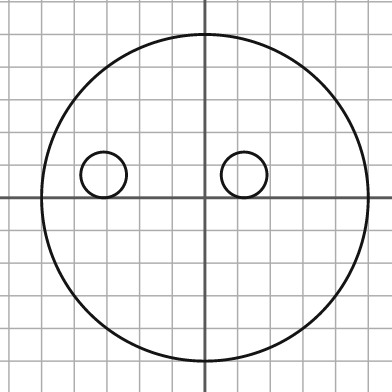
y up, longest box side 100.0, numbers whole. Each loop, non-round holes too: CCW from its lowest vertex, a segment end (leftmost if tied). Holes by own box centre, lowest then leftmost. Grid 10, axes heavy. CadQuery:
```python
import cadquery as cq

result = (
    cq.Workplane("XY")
    .moveTo(0.0, 0.0)
    .circle(50.0)
    .moveTo(-31.0, 7.0)
    .circle(7.0)
    .moveTo(12.0, 7.0)
    .circle(7.0)
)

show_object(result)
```